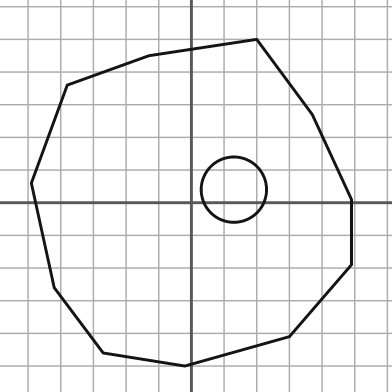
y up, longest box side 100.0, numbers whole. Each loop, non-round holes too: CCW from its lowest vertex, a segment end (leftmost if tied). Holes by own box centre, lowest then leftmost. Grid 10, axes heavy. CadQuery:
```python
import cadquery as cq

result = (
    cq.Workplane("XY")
    .moveTo(-2.0, -50.0)
    .lineTo(30.0, -41.0)
    .lineTo(49.0, -19.0)
    .lineTo(49.0, 1.0)
    .lineTo(37.0, 27.0)
    .lineTo(20.0, 50.0)
    .lineTo(-13.0, 45.0)
    .lineTo(-38.0, 36.0)
    .lineTo(-49.0, 6.0)
    .lineTo(-42.0, -26.0)
    .lineTo(-27.0, -46.0)
    .close()
    .moveTo(13.0, 4.0)
    .circle(10.0)
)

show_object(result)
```